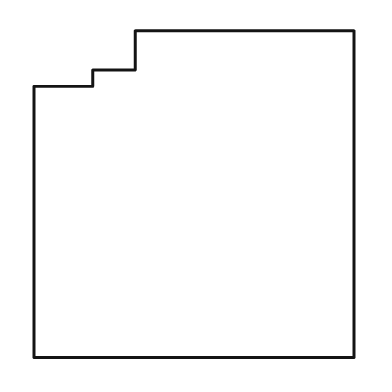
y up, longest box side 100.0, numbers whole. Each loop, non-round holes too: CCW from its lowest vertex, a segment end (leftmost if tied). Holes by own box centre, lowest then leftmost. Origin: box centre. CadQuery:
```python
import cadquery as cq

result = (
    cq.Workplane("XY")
    .moveTo(-49.0, -50.0)
    .lineTo(49.0, -50.0)
    .lineTo(49.0, 50.0)
    .lineTo(-18.0, 50.0)
    .lineTo(-18.0, 38.0)
    .lineTo(-31.0, 38.0)
    .lineTo(-31.0, 33.0)
    .lineTo(-49.0, 33.0)
    .close()
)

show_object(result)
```